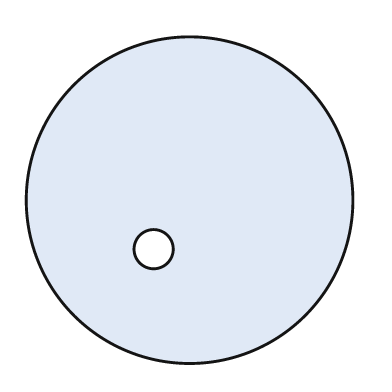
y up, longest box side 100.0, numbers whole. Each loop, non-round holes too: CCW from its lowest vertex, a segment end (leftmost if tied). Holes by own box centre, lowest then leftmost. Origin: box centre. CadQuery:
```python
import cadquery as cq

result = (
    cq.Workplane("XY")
    .moveTo(0.0, 0.0)
    .circle(50.0)
    .moveTo(-11.0, -15.0)
    .circle(6.0)
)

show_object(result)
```